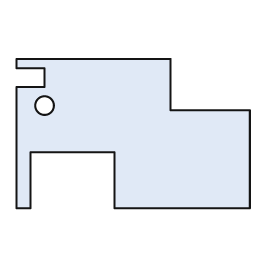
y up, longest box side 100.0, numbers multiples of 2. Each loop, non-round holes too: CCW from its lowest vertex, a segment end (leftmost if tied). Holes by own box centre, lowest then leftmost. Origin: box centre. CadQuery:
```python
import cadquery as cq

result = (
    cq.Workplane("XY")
    .moveTo(-50.0, -32.0)
    .lineTo(-44.0, -32.0)
    .lineTo(-44.0, -8.0)
    .lineTo(-8.0, -8.0)
    .lineTo(-8.0, -32.0)
    .lineTo(50.0, -32.0)
    .lineTo(50.0, 10.0)
    .lineTo(16.0, 10.0)
    .lineTo(16.0, 32.0)
    .lineTo(-50.0, 32.0)
    .lineTo(-50.0, 28.0)
    .lineTo(-38.0, 28.0)
    .lineTo(-38.0, 20.0)
    .lineTo(-50.0, 20.0)
    .close()
    .moveTo(-38.0, 12.0)
    .circle(4.0)
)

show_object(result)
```